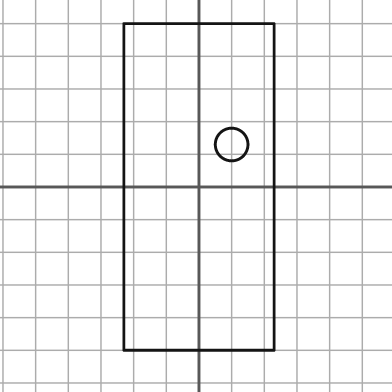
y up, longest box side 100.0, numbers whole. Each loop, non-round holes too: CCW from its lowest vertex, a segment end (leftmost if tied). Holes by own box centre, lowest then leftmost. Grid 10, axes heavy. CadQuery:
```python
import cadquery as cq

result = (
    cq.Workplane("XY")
    .moveTo(-23.0, -50.0)
    .lineTo(23.0, -50.0)
    .lineTo(23.0, 50.0)
    .lineTo(-23.0, 50.0)
    .close()
    .moveTo(10.0, 13.0)
    .circle(5.0)
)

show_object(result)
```